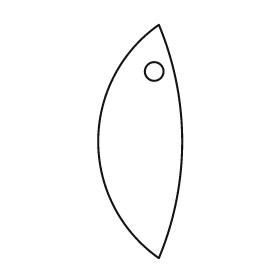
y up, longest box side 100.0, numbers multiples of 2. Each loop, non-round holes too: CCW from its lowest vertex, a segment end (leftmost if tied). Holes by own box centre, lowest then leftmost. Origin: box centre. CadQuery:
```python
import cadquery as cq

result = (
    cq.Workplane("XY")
    .moveTo(8.0, -50.0)
    .threePointArc((18.0, 0.0), (8.0, 50.0))
    .threePointArc((-18.0, 0.0), (8.0, -50.0))
    .close()
    .moveTo(6.0, 30.0)
    .circle(4.0)
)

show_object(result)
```